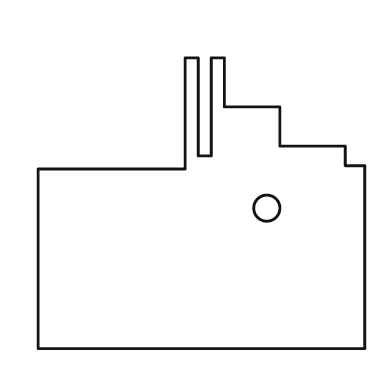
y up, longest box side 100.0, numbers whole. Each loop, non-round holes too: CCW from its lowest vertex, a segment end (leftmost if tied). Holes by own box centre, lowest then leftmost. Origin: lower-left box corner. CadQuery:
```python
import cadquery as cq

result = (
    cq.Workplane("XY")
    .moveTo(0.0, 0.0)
    .lineTo(100.0, 0.0)
    .lineTo(100.0, 56.0)
    .lineTo(94.0, 56.0)
    .lineTo(94.0, 62.0)
    .lineTo(74.0, 62.0)
    .lineTo(74.0, 74.0)
    .lineTo(57.0, 74.0)
    .lineTo(57.0, 89.0)
    .lineTo(53.0, 89.0)
    .lineTo(53.0, 59.0)
    .lineTo(49.0, 59.0)
    .lineTo(49.0, 89.0)
    .lineTo(45.0, 89.0)
    .lineTo(45.0, 55.0)
    .lineTo(0.0, 55.0)
    .close()
    .moveTo(70.0, 43.0)
    .circle(4.0)
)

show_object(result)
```